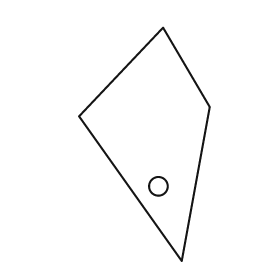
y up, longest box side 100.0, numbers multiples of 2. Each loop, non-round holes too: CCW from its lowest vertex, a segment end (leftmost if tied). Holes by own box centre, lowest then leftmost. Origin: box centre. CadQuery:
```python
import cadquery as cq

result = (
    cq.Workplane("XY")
    .moveTo(16.0, -50.0)
    .lineTo(28.0, 16.0)
    .lineTo(8.0, 50.0)
    .lineTo(-28.0, 12.0)
    .close()
    .moveTo(6.0, -18.0)
    .circle(4.0)
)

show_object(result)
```